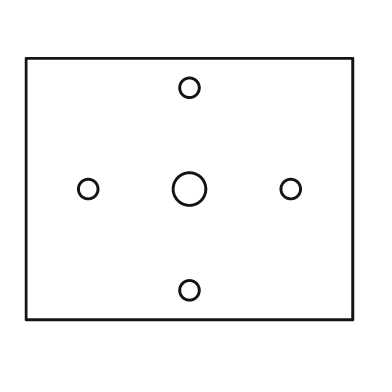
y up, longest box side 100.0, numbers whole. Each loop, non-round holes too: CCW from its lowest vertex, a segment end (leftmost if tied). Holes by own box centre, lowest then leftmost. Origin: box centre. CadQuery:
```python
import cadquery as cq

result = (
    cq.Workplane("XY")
    .moveTo(-50.0, -40.0)
    .lineTo(50.0, -40.0)
    .lineTo(50.0, 40.0)
    .lineTo(-50.0, 40.0)
    .close()
    .moveTo(0.0, -31.0)
    .circle(3.0)
    .moveTo(-31.0, 0.0)
    .circle(3.0)
    .moveTo(0.0, 0.0)
    .circle(5.0)
    .moveTo(31.0, 0.0)
    .circle(3.0)
    .moveTo(0.0, 31.0)
    .circle(3.0)
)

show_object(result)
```